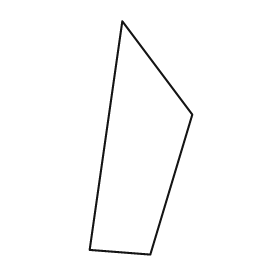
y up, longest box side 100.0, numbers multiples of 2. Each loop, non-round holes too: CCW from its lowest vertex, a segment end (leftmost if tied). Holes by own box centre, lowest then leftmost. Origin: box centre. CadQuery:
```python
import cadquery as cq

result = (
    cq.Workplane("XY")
    .moveTo(4.0, -50.0)
    .lineTo(22.0, 10.0)
    .lineTo(-8.0, 50.0)
    .lineTo(-22.0, -48.0)
    .close()
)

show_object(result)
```